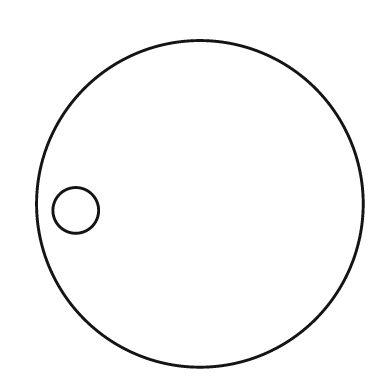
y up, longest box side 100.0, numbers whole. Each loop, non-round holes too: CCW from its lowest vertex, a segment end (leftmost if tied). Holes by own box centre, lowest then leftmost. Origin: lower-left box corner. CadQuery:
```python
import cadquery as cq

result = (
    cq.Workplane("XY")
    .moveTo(50.0, 50.0)
    .circle(50.0)
    .moveTo(12.0, 48.0)
    .circle(7.0)
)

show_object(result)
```